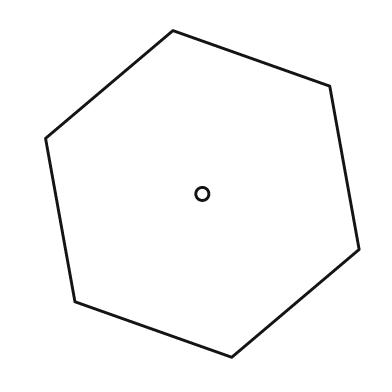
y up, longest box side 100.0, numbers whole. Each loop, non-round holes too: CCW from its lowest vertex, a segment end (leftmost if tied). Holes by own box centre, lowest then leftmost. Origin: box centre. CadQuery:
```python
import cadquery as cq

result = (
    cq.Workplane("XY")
    .moveTo(9.0, -50.0)
    .lineTo(48.0, -17.0)
    .lineTo(39.0, 33.0)
    .lineTo(-9.0, 50.0)
    .lineTo(-48.0, 17.0)
    .lineTo(-39.0, -33.0)
    .close()
    .moveTo(0.0, 0.0)
    .circle(2.0)
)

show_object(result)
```